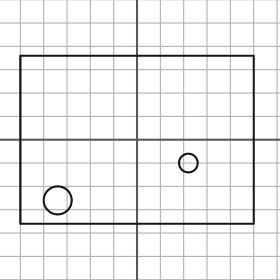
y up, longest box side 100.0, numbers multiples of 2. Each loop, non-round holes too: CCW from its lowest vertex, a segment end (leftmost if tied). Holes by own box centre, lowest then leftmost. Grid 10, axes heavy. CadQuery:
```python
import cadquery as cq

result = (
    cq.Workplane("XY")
    .moveTo(-50.0, -36.0)
    .lineTo(50.0, -36.0)
    .lineTo(50.0, 36.0)
    .lineTo(-50.0, 36.0)
    .close()
    .moveTo(-34.0, -26.0)
    .circle(6.0)
    .moveTo(22.0, -10.0)
    .circle(4.0)
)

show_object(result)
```